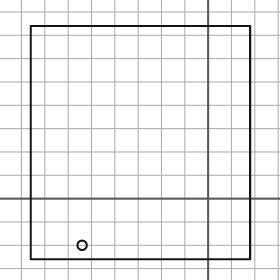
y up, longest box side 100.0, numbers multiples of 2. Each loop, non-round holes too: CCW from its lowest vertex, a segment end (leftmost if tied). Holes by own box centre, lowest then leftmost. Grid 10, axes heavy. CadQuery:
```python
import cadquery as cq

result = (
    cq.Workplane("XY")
    .moveTo(-76.0, -26.0)
    .lineTo(18.0, -26.0)
    .lineTo(18.0, 74.0)
    .lineTo(-76.0, 74.0)
    .close()
    .moveTo(-54.0, -20.0)
    .circle(2.0)
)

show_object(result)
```